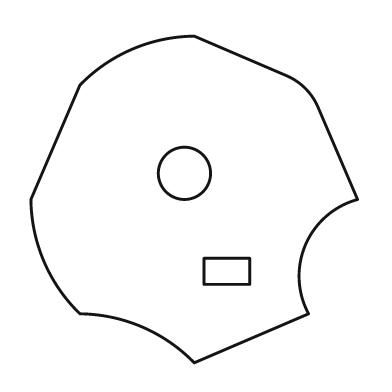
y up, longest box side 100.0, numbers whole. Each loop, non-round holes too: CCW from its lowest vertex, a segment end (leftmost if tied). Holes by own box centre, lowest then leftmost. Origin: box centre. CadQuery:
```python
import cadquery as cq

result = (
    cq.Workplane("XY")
    .moveTo(0.0, -50.0)
    .lineTo(35.0, -35.0)
    .threePointArc((34.0, -14.0), (50.0, 0.0))
    .lineTo(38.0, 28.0)
    .threePointArc((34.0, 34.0), (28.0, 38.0))
    .lineTo(0.0, 50.0)
    .threePointArc((-19.0, 46.0), (-35.0, 35.0))
    .lineTo(-50.0, 0.0)
    .threePointArc((-46.0, -19.0), (-35.0, -35.0))
    .threePointArc((-16.0, -39.0), (0.0, -50.0))
    .close()
    .moveTo(3.0, -26.0)
    .lineTo(17.0, -26.0)
    .lineTo(17.0, -18.0)
    .lineTo(3.0, -18.0)
    .close()
    .moveTo(-3.0, 8.0)
    .circle(8.0)
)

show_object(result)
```